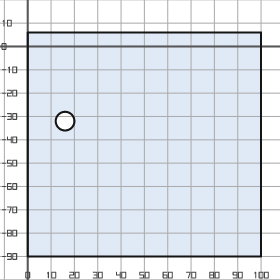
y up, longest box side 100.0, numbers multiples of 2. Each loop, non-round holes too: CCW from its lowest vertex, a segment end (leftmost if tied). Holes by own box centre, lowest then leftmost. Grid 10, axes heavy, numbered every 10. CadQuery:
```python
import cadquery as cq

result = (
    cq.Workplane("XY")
    .moveTo(0.0, -90.0)
    .lineTo(100.0, -90.0)
    .lineTo(100.0, 6.0)
    .lineTo(0.0, 6.0)
    .close()
    .moveTo(16.0, -32.0)
    .circle(4.0)
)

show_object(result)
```